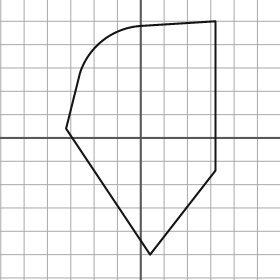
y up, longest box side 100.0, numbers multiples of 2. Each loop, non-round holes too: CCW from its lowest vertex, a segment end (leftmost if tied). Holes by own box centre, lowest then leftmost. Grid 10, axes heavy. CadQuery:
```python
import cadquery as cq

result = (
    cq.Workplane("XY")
    .moveTo(4.0, -50.0)
    .lineTo(32.0, -14.0)
    .lineTo(32.0, 50.0)
    .lineTo(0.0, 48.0)
    .threePointArc((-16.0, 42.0), (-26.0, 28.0))
    .lineTo(-32.0, 4.0)
    .close()
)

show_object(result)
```